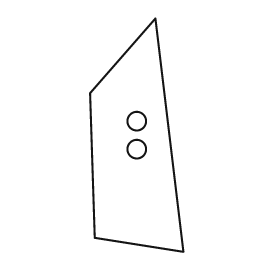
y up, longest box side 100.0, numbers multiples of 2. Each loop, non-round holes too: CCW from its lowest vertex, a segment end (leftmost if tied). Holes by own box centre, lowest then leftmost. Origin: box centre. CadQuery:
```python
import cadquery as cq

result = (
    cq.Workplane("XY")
    .moveTo(20.0, -50.0)
    .lineTo(8.0, 50.0)
    .lineTo(-20.0, 18.0)
    .lineTo(-18.0, -44.0)
    .close()
    .moveTo(0.0, -6.0)
    .circle(4.0)
    .moveTo(0.0, 6.0)
    .circle(4.0)
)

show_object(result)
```